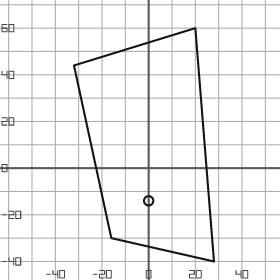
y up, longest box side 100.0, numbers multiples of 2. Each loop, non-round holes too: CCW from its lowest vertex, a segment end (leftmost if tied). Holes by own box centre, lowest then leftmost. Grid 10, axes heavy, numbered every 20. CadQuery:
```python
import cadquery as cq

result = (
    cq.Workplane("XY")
    .moveTo(28.0, -40.0)
    .lineTo(20.0, 60.0)
    .lineTo(-32.0, 44.0)
    .lineTo(-16.0, -30.0)
    .close()
    .moveTo(0.0, -14.0)
    .circle(2.0)
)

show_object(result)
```